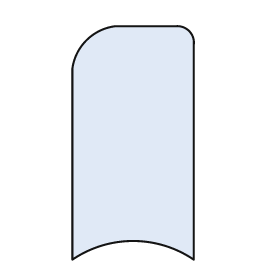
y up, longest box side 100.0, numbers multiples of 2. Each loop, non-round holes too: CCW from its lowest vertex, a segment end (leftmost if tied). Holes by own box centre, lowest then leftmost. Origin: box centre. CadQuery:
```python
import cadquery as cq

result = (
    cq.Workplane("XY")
    .moveTo(-26.0, -50.0)
    .threePointArc((0.0, -42.0), (26.0, -50.0))
    .lineTo(26.0, 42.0)
    .threePointArc((24.0, 48.0), (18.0, 50.0))
    .lineTo(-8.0, 50.0)
    .threePointArc((-20.0, 44.0), (-26.0, 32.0))
    .close()
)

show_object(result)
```